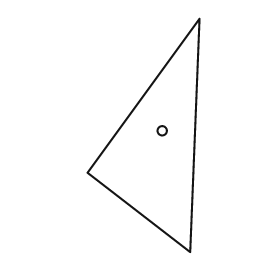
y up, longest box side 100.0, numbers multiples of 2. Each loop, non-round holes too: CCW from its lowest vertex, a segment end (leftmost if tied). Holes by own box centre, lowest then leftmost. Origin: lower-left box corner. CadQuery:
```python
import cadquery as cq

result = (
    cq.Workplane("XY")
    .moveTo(44.0, 0.0)
    .lineTo(48.0, 100.0)
    .lineTo(0.0, 34.0)
    .close()
    .moveTo(32.0, 52.0)
    .circle(2.0)
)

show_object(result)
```